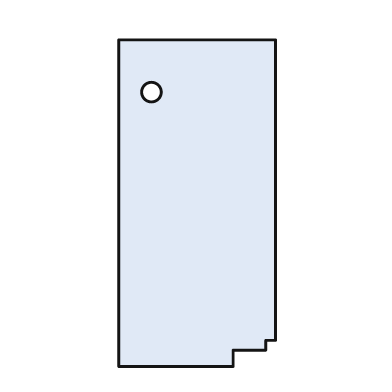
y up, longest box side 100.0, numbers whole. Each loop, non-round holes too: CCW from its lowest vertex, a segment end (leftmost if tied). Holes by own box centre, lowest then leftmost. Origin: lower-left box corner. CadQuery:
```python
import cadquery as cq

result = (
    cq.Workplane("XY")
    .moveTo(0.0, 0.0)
    .lineTo(35.0, 0.0)
    .lineTo(35.0, 5.0)
    .lineTo(45.0, 5.0)
    .lineTo(45.0, 8.0)
    .lineTo(48.0, 8.0)
    .lineTo(48.0, 100.0)
    .lineTo(0.0, 100.0)
    .close()
    .moveTo(10.0, 84.0)
    .circle(3.0)
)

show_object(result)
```